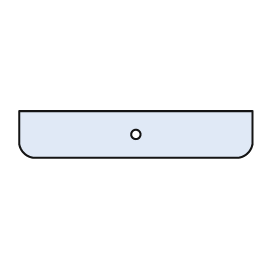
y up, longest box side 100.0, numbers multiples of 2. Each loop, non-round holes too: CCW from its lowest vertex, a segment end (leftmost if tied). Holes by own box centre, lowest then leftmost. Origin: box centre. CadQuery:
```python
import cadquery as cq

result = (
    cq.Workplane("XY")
    .moveTo(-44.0, -10.0)
    .lineTo(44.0, -10.0)
    .threePointArc((48.0, -8.0), (50.0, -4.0))
    .lineTo(50.0, 10.0)
    .lineTo(-50.0, 10.0)
    .lineTo(-50.0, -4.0)
    .threePointArc((-48.0, -8.0), (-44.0, -10.0))
    .close()
    .moveTo(0.0, 0.0)
    .circle(2.0)
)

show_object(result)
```